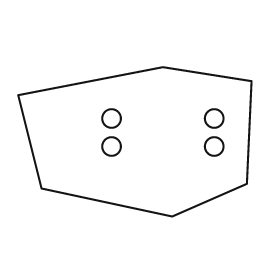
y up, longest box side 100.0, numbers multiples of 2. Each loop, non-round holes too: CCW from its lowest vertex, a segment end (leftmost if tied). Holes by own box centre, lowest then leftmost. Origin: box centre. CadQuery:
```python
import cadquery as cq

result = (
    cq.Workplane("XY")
    .moveTo(16.0, -32.0)
    .lineTo(48.0, -18.0)
    .lineTo(50.0, 26.0)
    .lineTo(12.0, 32.0)
    .lineTo(-50.0, 20.0)
    .lineTo(-40.0, -20.0)
    .close()
    .moveTo(-10.0, -2.0)
    .circle(4.0)
    .moveTo(34.0, -2.0)
    .circle(4.0)
    .moveTo(-10.0, 10.0)
    .circle(4.0)
    .moveTo(34.0, 10.0)
    .circle(4.0)
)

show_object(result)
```